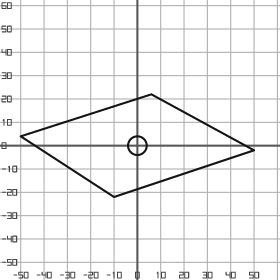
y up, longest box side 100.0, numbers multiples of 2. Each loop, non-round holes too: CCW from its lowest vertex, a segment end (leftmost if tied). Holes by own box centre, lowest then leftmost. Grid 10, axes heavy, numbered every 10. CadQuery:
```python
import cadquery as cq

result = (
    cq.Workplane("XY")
    .moveTo(-10.0, -22.0)
    .lineTo(50.0, -2.0)
    .lineTo(6.0, 22.0)
    .lineTo(-50.0, 4.0)
    .close()
    .moveTo(0.0, 0.0)
    .circle(4.0)
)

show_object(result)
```